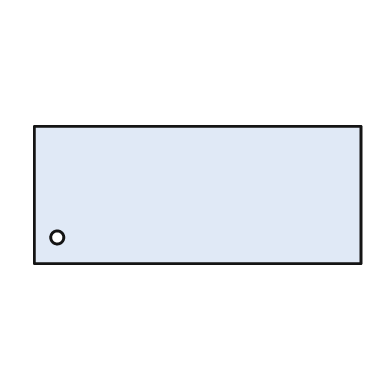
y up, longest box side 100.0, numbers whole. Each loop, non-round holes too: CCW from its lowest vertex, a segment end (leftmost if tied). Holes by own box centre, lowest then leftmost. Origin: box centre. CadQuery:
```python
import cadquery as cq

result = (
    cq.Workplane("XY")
    .moveTo(-50.0, -21.0)
    .lineTo(50.0, -21.0)
    .lineTo(50.0, 21.0)
    .lineTo(-50.0, 21.0)
    .close()
    .moveTo(-43.0, -13.0)
    .circle(2.0)
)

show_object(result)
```